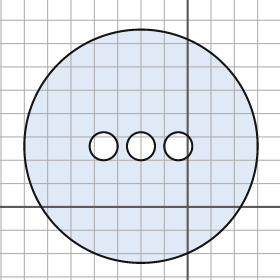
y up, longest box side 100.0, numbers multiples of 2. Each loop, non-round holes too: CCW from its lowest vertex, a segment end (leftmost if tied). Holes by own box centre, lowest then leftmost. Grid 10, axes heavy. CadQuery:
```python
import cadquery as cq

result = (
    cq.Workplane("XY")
    .moveTo(-20.0, 26.0)
    .circle(50.0)
    .moveTo(-36.0, 26.0)
    .circle(6.0)
    .moveTo(-20.0, 26.0)
    .circle(6.0)
    .moveTo(-4.0, 26.0)
    .circle(6.0)
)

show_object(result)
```